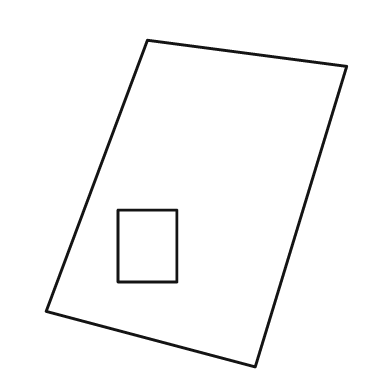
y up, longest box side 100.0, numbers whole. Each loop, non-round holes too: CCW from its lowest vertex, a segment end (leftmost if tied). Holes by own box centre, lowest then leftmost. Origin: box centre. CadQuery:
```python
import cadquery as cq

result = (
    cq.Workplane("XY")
    .moveTo(18.0, -50.0)
    .lineTo(46.0, 42.0)
    .lineTo(-15.0, 50.0)
    .lineTo(-46.0, -33.0)
    .close()
    .moveTo(-24.0, -24.0)
    .lineTo(-6.0, -24.0)
    .lineTo(-6.0, -2.0)
    .lineTo(-24.0, -2.0)
    .close()
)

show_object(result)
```